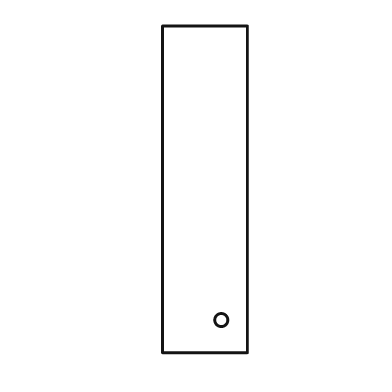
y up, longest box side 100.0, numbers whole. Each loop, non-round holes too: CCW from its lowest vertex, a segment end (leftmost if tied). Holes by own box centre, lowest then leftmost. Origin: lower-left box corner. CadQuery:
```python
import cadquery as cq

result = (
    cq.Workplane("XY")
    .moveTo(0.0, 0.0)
    .lineTo(26.0, 0.0)
    .lineTo(26.0, 100.0)
    .lineTo(0.0, 100.0)
    .close()
    .moveTo(18.0, 10.0)
    .circle(2.0)
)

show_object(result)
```